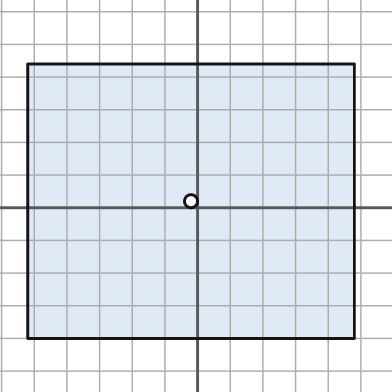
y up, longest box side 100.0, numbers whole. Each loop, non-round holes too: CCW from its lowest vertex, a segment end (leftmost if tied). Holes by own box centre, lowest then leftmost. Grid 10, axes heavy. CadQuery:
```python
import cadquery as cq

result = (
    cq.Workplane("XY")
    .moveTo(-52.0, -40.0)
    .lineTo(48.0, -40.0)
    .lineTo(48.0, 44.0)
    .lineTo(-52.0, 44.0)
    .close()
    .moveTo(-2.0, 2.0)
    .circle(2.0)
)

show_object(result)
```